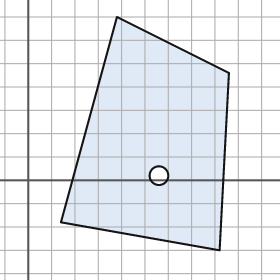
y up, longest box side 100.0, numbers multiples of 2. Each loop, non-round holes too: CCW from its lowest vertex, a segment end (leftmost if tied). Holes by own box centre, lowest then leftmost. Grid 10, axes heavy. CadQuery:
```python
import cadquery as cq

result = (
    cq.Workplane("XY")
    .moveTo(82.0, -30.0)
    .lineTo(86.0, 46.0)
    .lineTo(38.0, 70.0)
    .lineTo(14.0, -18.0)
    .close()
    .moveTo(56.0, 2.0)
    .circle(4.0)
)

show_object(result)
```